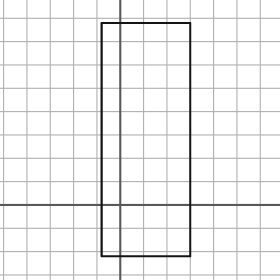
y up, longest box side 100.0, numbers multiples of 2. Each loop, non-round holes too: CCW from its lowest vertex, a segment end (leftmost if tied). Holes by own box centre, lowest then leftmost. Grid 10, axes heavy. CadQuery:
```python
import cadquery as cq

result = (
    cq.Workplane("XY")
    .moveTo(-8.0, -22.0)
    .lineTo(30.0, -22.0)
    .lineTo(30.0, 78.0)
    .lineTo(-8.0, 78.0)
    .close()
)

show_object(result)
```